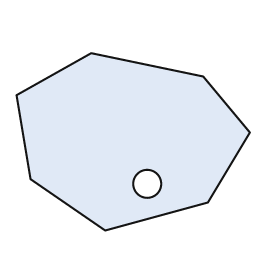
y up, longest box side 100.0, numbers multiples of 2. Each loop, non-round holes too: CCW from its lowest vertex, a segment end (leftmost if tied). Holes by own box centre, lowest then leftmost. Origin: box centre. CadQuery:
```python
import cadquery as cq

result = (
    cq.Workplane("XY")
    .moveTo(-12.0, -38.0)
    .lineTo(32.0, -26.0)
    .lineTo(50.0, 4.0)
    .lineTo(30.0, 28.0)
    .lineTo(-18.0, 38.0)
    .lineTo(-50.0, 20.0)
    .lineTo(-44.0, -16.0)
    .close()
    .moveTo(6.0, -18.0)
    .circle(6.0)
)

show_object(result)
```